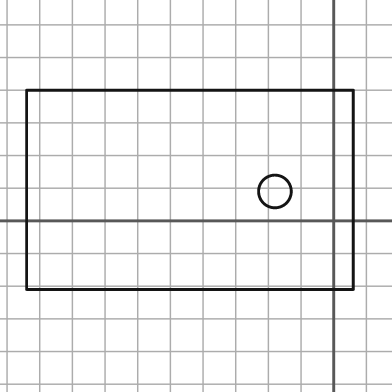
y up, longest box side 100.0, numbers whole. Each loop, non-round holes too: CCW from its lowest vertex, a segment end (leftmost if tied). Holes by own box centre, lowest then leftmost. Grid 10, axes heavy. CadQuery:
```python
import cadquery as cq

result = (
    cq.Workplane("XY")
    .moveTo(-94.0, -21.0)
    .lineTo(6.0, -21.0)
    .lineTo(6.0, 40.0)
    .lineTo(-94.0, 40.0)
    .close()
    .moveTo(-18.0, 9.0)
    .circle(5.0)
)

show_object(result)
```